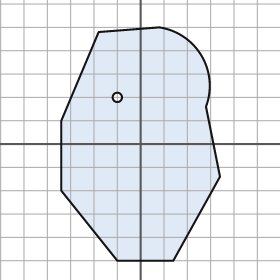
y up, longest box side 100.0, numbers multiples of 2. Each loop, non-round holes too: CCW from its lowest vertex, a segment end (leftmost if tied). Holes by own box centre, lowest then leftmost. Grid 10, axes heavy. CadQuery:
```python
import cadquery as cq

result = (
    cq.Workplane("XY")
    .moveTo(-10.0, -50.0)
    .lineTo(14.0, -50.0)
    .lineTo(34.0, -14.0)
    .lineTo(28.0, 16.0)
    .threePointArc((26.0, 38.0), (8.0, 50.0))
    .lineTo(-18.0, 48.0)
    .lineTo(-34.0, 10.0)
    .lineTo(-34.0, -20.0)
    .close()
    .moveTo(-10.0, 20.0)
    .circle(2.0)
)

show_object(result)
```